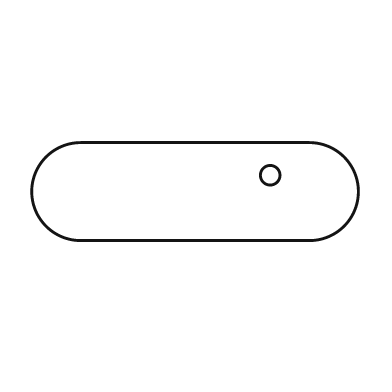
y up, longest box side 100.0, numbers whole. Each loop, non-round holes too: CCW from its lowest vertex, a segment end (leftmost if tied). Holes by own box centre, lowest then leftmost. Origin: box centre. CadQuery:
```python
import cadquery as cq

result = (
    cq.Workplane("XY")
    .moveTo(-35.0, -15.0)
    .lineTo(35.0, -15.0)
    .threePointArc((50.0, 0.0), (35.0, 15.0))
    .lineTo(-35.0, 15.0)
    .threePointArc((-50.0, 0.0), (-35.0, -15.0))
    .close()
    .moveTo(23.0, 5.0)
    .circle(3.0)
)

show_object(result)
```